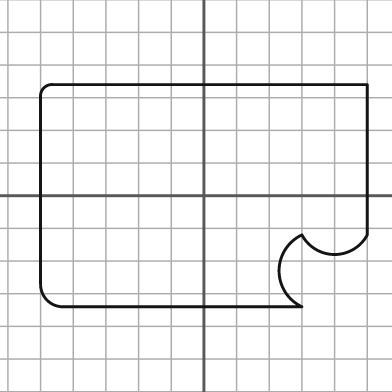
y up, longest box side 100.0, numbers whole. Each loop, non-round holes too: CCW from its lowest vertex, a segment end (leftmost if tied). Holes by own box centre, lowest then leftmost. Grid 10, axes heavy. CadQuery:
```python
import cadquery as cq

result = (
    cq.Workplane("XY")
    .moveTo(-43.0, -34.0)
    .lineTo(30.0, -34.0)
    .threePointArc((23.0, -23.0), (30.0, -12.0))
    .threePointArc((40.0, -18.0), (50.0, -12.0))
    .lineTo(50.0, 34.0)
    .lineTo(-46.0, 34.0)
    .threePointArc((-49.0, 33.0), (-50.0, 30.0))
    .lineTo(-50.0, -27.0)
    .threePointArc((-48.0, -32.0), (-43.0, -34.0))
    .close()
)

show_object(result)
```